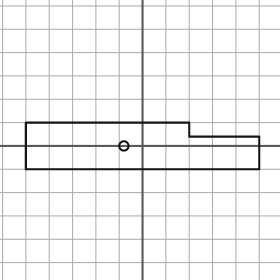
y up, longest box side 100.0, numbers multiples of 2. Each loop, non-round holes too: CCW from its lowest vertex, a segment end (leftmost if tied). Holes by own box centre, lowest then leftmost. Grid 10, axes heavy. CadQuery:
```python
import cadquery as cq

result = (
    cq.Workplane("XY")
    .moveTo(-50.0, -10.0)
    .lineTo(50.0, -10.0)
    .lineTo(50.0, 4.0)
    .lineTo(20.0, 4.0)
    .lineTo(20.0, 10.0)
    .lineTo(-50.0, 10.0)
    .close()
    .moveTo(-8.0, 0.0)
    .circle(2.0)
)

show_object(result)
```